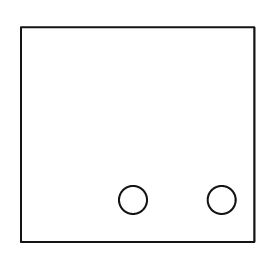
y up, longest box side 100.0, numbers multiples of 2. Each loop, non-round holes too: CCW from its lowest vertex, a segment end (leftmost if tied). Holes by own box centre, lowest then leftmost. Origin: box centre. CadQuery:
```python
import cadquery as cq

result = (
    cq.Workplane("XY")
    .moveTo(-50.0, -46.0)
    .lineTo(50.0, -46.0)
    .lineTo(50.0, 46.0)
    .lineTo(-50.0, 46.0)
    .close()
    .moveTo(-2.0, -28.0)
    .circle(6.0)
    .moveTo(36.0, -28.0)
    .circle(6.0)
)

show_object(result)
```